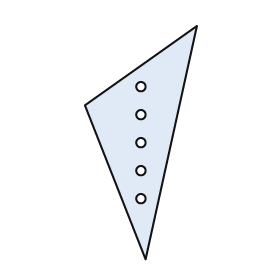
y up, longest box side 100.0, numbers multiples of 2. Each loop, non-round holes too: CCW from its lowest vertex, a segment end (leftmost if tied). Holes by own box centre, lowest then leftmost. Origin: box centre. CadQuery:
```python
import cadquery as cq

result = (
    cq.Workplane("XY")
    .moveTo(2.0, -50.0)
    .lineTo(24.0, 50.0)
    .lineTo(-24.0, 16.0)
    .close()
    .moveTo(0.0, -24.0)
    .circle(2.0)
    .moveTo(0.0, -12.0)
    .circle(2.0)
    .moveTo(0.0, 0.0)
    .circle(2.0)
    .moveTo(0.0, 12.0)
    .circle(2.0)
    .moveTo(0.0, 24.0)
    .circle(2.0)
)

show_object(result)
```